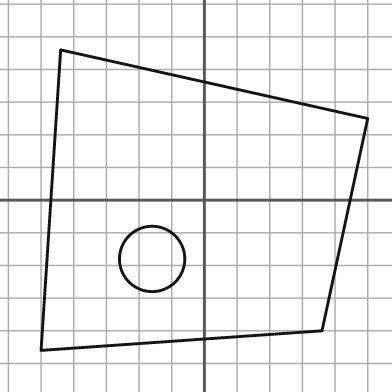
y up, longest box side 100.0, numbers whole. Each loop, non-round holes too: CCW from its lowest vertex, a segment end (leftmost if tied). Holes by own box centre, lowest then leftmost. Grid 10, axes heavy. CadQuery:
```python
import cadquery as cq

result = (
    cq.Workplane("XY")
    .moveTo(-50.0, -46.0)
    .lineTo(36.0, -40.0)
    .lineTo(50.0, 25.0)
    .lineTo(-44.0, 46.0)
    .close()
    .moveTo(-16.0, -18.0)
    .circle(10.0)
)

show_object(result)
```